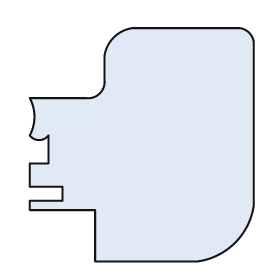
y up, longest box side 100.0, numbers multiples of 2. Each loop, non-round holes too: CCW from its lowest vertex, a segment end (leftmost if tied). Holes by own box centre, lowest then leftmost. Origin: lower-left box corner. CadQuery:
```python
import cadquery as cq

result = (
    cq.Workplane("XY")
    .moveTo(28.0, 0.0)
    .lineTo(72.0, 0.0)
    .threePointArc((88.0, 8.0), (96.0, 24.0))
    .lineTo(96.0, 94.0)
    .threePointArc((94.0, 98.0), (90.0, 100.0))
    .lineTo(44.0, 100.0)
    .threePointArc((36.0, 96.0), (32.0, 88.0))
    .lineTo(32.0, 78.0)
    .threePointArc((30.0, 72.0), (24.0, 70.0))
    .lineTo(0.0, 70.0)
    .threePointArc((2.0, 62.0), (0.0, 54.0))
    .threePointArc((4.0, 52.0), (8.0, 54.0))
    .lineTo(8.0, 42.0)
    .lineTo(0.0, 42.0)
    .lineTo(0.0, 32.0)
    .lineTo(14.0, 32.0)
    .lineTo(14.0, 26.0)
    .lineTo(0.0, 26.0)
    .lineTo(0.0, 22.0)
    .lineTo(28.0, 22.0)
    .close()
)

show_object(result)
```